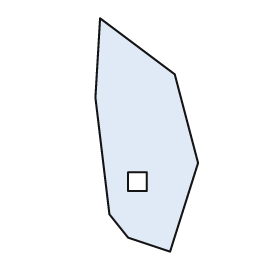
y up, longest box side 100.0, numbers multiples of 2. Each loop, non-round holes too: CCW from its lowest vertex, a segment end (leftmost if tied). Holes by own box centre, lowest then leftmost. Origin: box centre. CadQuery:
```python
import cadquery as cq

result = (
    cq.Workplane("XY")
    .moveTo(10.0, -50.0)
    .lineTo(22.0, -12.0)
    .lineTo(12.0, 26.0)
    .lineTo(-20.0, 50.0)
    .lineTo(-22.0, 16.0)
    .lineTo(-16.0, -34.0)
    .lineTo(-8.0, -44.0)
    .close()
    .moveTo(-8.0, -24.0)
    .lineTo(0.0, -24.0)
    .lineTo(0.0, -16.0)
    .lineTo(-8.0, -16.0)
    .close()
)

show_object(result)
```